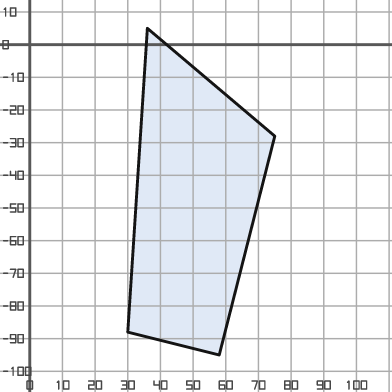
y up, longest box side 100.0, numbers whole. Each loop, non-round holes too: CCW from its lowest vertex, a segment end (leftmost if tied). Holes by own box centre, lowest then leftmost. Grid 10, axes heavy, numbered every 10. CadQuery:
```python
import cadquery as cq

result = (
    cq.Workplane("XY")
    .moveTo(58.0, -95.0)
    .lineTo(75.0, -28.0)
    .lineTo(36.0, 5.0)
    .lineTo(30.0, -88.0)
    .close()
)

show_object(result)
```